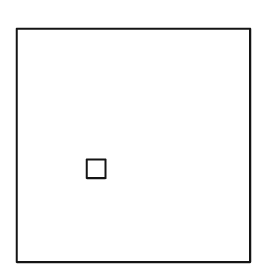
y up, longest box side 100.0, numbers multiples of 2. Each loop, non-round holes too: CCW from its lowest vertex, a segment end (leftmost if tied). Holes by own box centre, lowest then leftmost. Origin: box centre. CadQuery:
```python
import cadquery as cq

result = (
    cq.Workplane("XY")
    .moveTo(-50.0, -50.0)
    .lineTo(50.0, -50.0)
    .lineTo(50.0, 50.0)
    .lineTo(-50.0, 50.0)
    .close()
    .moveTo(-20.0, -14.0)
    .lineTo(-12.0, -14.0)
    .lineTo(-12.0, -6.0)
    .lineTo(-20.0, -6.0)
    .close()
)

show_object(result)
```